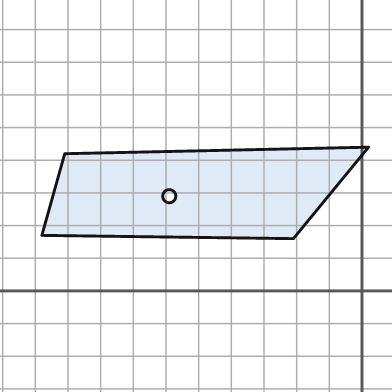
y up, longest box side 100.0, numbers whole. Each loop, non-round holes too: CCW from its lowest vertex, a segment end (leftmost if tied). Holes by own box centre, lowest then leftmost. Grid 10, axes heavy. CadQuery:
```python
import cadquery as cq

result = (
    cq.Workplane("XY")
    .moveTo(-21.0, 16.0)
    .lineTo(2.0, 44.0)
    .lineTo(-91.0, 42.0)
    .lineTo(-98.0, 17.0)
    .close()
    .moveTo(-59.0, 29.0)
    .circle(2.0)
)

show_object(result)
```